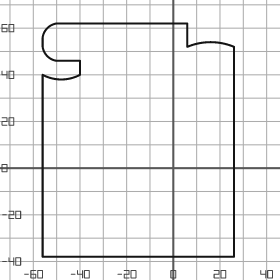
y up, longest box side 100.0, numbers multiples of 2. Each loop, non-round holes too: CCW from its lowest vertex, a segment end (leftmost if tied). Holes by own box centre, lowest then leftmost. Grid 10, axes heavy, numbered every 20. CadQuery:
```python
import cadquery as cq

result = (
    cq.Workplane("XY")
    .moveTo(-56.0, -38.0)
    .lineTo(26.0, -38.0)
    .lineTo(26.0, 52.0)
    .threePointArc((16.0, 54.0), (6.0, 52.0))
    .lineTo(6.0, 62.0)
    .lineTo(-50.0, 62.0)
    .threePointArc((-54.0, 60.0), (-56.0, 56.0))
    .lineTo(-56.0, 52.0)
    .threePointArc((-54.0, 48.0), (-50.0, 46.0))
    .lineTo(-40.0, 46.0)
    .lineTo(-40.0, 40.0)
    .threePointArc((-48.0, 38.0), (-56.0, 40.0))
    .close()
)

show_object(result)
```